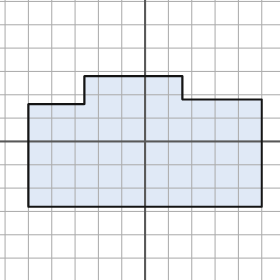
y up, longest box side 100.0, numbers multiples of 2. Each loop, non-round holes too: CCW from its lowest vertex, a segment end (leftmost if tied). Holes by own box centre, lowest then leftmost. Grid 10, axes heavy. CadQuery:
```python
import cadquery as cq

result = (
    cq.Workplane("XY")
    .moveTo(-50.0, -28.0)
    .lineTo(50.0, -28.0)
    .lineTo(50.0, 18.0)
    .lineTo(16.0, 18.0)
    .lineTo(16.0, 28.0)
    .lineTo(-26.0, 28.0)
    .lineTo(-26.0, 16.0)
    .lineTo(-50.0, 16.0)
    .close()
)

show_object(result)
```